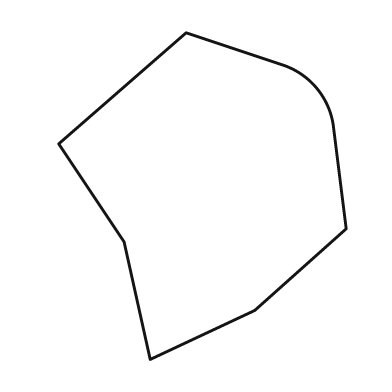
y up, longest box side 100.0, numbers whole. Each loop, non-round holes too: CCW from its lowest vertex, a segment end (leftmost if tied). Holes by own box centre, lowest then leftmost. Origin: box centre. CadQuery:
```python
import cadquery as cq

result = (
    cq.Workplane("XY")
    .moveTo(-16.0, -50.0)
    .lineTo(16.0, -35.0)
    .lineTo(44.0, -10.0)
    .lineTo(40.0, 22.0)
    .threePointArc((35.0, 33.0), (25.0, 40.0))
    .lineTo(-5.0, 50.0)
    .lineTo(-44.0, 16.0)
    .lineTo(-24.0, -14.0)
    .close()
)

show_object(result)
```